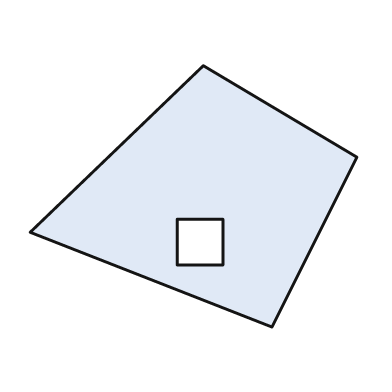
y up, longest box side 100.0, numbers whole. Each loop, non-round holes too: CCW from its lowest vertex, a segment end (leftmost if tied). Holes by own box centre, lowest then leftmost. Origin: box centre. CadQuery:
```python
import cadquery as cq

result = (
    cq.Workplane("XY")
    .moveTo(24.0, -40.0)
    .lineTo(50.0, 12.0)
    .lineTo(3.0, 40.0)
    .lineTo(-50.0, -11.0)
    .close()
    .moveTo(-5.0, -21.0)
    .lineTo(9.0, -21.0)
    .lineTo(9.0, -7.0)
    .lineTo(-5.0, -7.0)
    .close()
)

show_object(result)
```